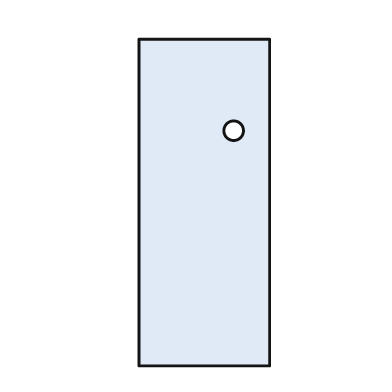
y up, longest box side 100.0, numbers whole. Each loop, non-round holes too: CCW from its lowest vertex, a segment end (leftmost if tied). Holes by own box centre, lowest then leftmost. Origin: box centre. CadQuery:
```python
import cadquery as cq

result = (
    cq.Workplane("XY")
    .moveTo(-20.0, -50.0)
    .lineTo(20.0, -50.0)
    .lineTo(20.0, 50.0)
    .lineTo(-20.0, 50.0)
    .close()
    .moveTo(9.0, 22.0)
    .circle(3.0)
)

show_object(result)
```